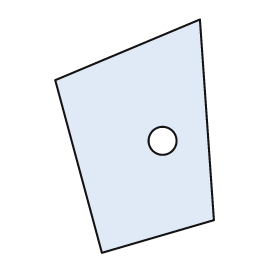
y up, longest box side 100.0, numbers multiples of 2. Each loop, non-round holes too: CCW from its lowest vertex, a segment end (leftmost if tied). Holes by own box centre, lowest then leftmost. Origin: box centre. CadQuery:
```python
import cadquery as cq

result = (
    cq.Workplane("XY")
    .moveTo(-14.0, -50.0)
    .lineTo(34.0, -36.0)
    .lineTo(28.0, 50.0)
    .lineTo(-34.0, 24.0)
    .close()
    .moveTo(12.0, -2.0)
    .circle(6.0)
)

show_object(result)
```